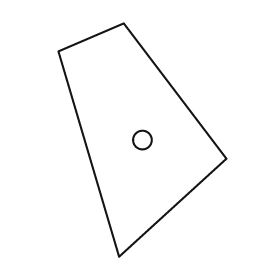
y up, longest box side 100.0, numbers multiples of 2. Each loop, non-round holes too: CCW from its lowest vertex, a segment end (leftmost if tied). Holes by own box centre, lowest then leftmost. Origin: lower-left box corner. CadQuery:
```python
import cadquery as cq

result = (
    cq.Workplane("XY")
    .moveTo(26.0, 0.0)
    .lineTo(72.0, 42.0)
    .lineTo(28.0, 100.0)
    .lineTo(0.0, 88.0)
    .close()
    .moveTo(36.0, 50.0)
    .circle(4.0)
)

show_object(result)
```